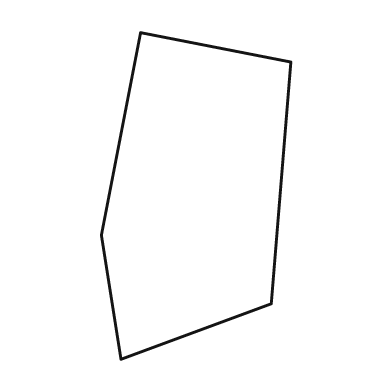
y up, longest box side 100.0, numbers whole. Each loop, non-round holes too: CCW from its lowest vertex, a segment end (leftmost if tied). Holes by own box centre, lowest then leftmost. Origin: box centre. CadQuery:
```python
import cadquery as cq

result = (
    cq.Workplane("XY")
    .moveTo(-23.0, -50.0)
    .lineTo(23.0, -33.0)
    .lineTo(29.0, 41.0)
    .lineTo(-17.0, 50.0)
    .lineTo(-29.0, -12.0)
    .close()
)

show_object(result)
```